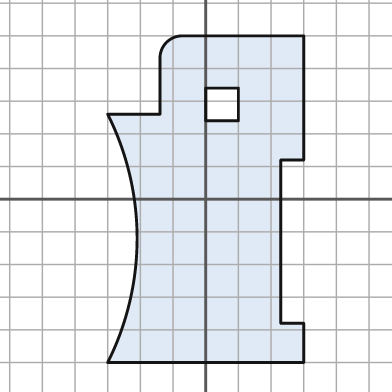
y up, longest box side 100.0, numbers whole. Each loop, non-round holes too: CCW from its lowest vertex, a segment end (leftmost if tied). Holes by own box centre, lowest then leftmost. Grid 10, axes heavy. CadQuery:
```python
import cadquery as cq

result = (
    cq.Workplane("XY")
    .moveTo(-30.0, -50.0)
    .lineTo(30.0, -50.0)
    .lineTo(30.0, -38.0)
    .lineTo(23.0, -38.0)
    .lineTo(23.0, 12.0)
    .lineTo(30.0, 12.0)
    .lineTo(30.0, 50.0)
    .lineTo(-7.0, 50.0)
    .threePointArc((-12.0, 48.0), (-14.0, 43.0))
    .lineTo(-14.0, 26.0)
    .lineTo(-30.0, 26.0)
    .threePointArc((-21.0, -12.0), (-30.0, -50.0))
    .close()
    .moveTo(0.0, 24.0)
    .lineTo(10.0, 24.0)
    .lineTo(10.0, 34.0)
    .lineTo(0.0, 34.0)
    .close()
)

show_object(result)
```